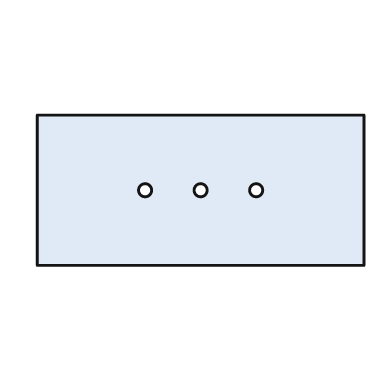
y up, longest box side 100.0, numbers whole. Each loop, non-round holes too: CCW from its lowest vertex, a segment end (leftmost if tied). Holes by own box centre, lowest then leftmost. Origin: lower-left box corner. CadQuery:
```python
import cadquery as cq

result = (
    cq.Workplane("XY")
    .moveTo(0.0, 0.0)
    .lineTo(100.0, 0.0)
    .lineTo(100.0, 46.0)
    .lineTo(0.0, 46.0)
    .close()
    .moveTo(33.0, 23.0)
    .circle(2.0)
    .moveTo(50.0, 23.0)
    .circle(2.0)
    .moveTo(67.0, 23.0)
    .circle(2.0)
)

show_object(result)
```